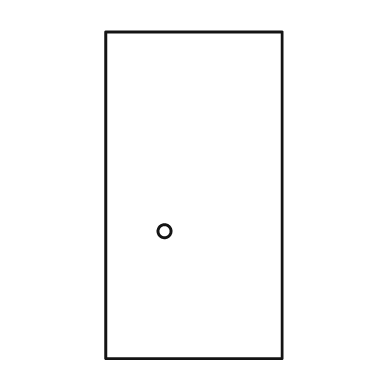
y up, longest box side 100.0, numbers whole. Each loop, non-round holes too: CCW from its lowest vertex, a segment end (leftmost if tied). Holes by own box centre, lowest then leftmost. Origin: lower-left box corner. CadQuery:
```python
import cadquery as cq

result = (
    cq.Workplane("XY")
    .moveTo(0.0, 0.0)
    .lineTo(54.0, 0.0)
    .lineTo(54.0, 100.0)
    .lineTo(0.0, 100.0)
    .close()
    .moveTo(18.0, 39.0)
    .circle(2.0)
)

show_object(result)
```